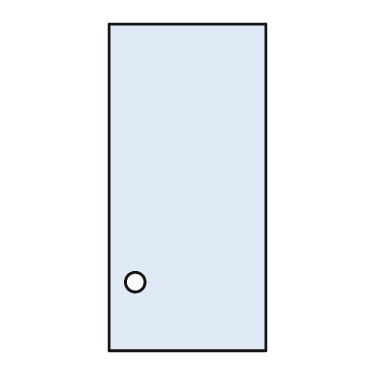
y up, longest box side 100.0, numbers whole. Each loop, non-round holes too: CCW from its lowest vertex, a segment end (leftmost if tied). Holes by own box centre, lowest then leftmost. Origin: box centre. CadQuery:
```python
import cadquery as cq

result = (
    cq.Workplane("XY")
    .moveTo(-24.0, -50.0)
    .lineTo(24.0, -50.0)
    .lineTo(24.0, 50.0)
    .lineTo(-24.0, 50.0)
    .close()
    .moveTo(-16.0, -29.0)
    .circle(3.0)
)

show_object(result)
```